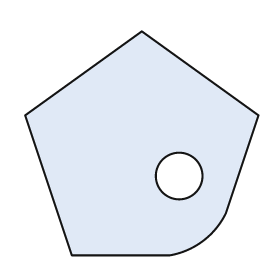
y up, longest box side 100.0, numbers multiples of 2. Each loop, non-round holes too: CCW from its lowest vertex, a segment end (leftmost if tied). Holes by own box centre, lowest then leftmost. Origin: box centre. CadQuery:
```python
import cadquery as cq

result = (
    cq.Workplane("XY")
    .moveTo(-30.0, -48.0)
    .lineTo(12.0, -48.0)
    .threePointArc((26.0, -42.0), (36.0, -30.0))
    .lineTo(50.0, 12.0)
    .lineTo(0.0, 48.0)
    .lineTo(-50.0, 12.0)
    .close()
    .moveTo(16.0, -14.0)
    .circle(10.0)
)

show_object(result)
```